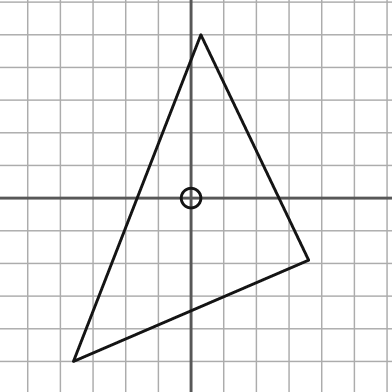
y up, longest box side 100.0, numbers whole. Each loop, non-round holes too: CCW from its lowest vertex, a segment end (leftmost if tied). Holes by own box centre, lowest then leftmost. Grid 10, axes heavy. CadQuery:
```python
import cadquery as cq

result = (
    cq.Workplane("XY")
    .moveTo(-36.0, -50.0)
    .lineTo(36.0, -19.0)
    .lineTo(3.0, 50.0)
    .close()
    .moveTo(0.0, 0.0)
    .circle(3.0)
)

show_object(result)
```